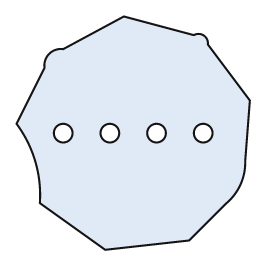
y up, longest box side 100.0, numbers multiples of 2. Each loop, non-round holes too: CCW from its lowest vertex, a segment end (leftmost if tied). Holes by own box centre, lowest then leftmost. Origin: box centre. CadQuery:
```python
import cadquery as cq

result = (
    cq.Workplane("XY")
    .moveTo(-12.0, -50.0)
    .lineTo(24.0, -46.0)
    .lineTo(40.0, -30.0)
    .threePointArc((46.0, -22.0), (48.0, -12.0))
    .lineTo(50.0, 14.0)
    .lineTo(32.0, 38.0)
    .threePointArc((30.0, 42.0), (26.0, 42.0))
    .lineTo(-4.0, 50.0)
    .lineTo(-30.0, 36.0)
    .threePointArc((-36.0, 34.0), (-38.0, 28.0))
    .lineTo(-50.0, 4.0)
    .threePointArc((-42.0, -12.0), (-40.0, -30.0))
    .close()
    .moveTo(-30.0, 0.0)
    .circle(4.0)
    .moveTo(-10.0, 0.0)
    .circle(4.0)
    .moveTo(10.0, 0.0)
    .circle(4.0)
    .moveTo(30.0, 0.0)
    .circle(4.0)
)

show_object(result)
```